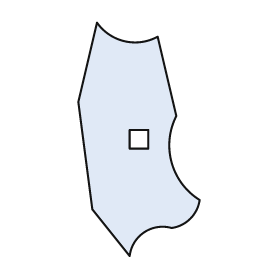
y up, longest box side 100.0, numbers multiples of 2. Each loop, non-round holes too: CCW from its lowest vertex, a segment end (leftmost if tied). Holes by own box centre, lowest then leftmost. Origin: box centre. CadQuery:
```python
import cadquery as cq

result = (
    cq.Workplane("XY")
    .moveTo(-4.0, -50.0)
    .threePointArc((2.0, -40.0), (14.0, -38.0))
    .threePointArc((22.0, -34.0), (26.0, -26.0))
    .threePointArc((14.0, -10.0), (16.0, 10.0))
    .lineTo(8.0, 44.0)
    .threePointArc((-6.0, 42.0), (-18.0, 50.0))
    .lineTo(-26.0, 16.0)
    .lineTo(-20.0, -30.0)
    .close()
    .moveTo(-4.0, -4.0)
    .lineTo(4.0, -4.0)
    .lineTo(4.0, 4.0)
    .lineTo(-4.0, 4.0)
    .close()
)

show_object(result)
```